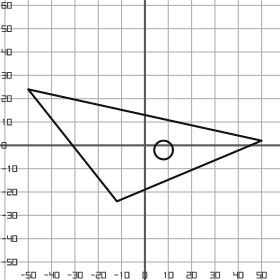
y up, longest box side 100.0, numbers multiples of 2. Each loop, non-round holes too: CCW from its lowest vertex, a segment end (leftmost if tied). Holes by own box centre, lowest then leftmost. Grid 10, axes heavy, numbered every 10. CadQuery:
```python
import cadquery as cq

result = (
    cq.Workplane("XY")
    .moveTo(-12.0, -24.0)
    .lineTo(50.0, 2.0)
    .lineTo(-50.0, 24.0)
    .close()
    .moveTo(8.0, -2.0)
    .circle(4.0)
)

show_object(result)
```